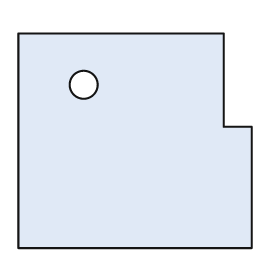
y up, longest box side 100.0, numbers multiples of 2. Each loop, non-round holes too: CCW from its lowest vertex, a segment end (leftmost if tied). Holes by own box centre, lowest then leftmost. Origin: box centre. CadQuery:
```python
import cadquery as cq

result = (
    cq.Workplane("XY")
    .moveTo(-50.0, -46.0)
    .lineTo(50.0, -46.0)
    .lineTo(50.0, 6.0)
    .lineTo(38.0, 6.0)
    .lineTo(38.0, 46.0)
    .lineTo(-50.0, 46.0)
    .close()
    .moveTo(-22.0, 24.0)
    .circle(6.0)
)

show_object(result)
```